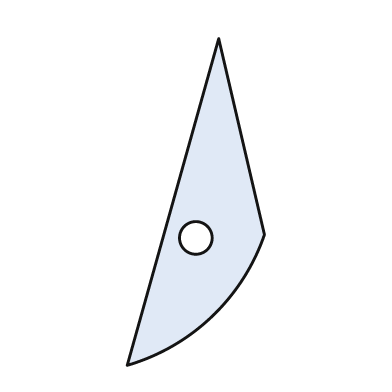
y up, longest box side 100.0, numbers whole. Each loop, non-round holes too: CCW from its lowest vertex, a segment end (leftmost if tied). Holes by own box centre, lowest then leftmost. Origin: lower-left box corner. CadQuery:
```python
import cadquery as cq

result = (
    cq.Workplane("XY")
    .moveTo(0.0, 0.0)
    .threePointArc((26.0, 15.0), (42.0, 40.0))
    .lineTo(28.0, 100.0)
    .close()
    .moveTo(21.0, 39.0)
    .circle(5.0)
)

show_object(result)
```